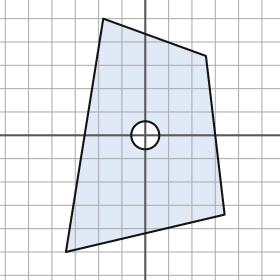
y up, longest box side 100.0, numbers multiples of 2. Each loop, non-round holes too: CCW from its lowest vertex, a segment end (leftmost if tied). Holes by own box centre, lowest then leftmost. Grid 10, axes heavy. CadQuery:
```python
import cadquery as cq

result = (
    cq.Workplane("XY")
    .moveTo(-34.0, -50.0)
    .lineTo(34.0, -34.0)
    .lineTo(26.0, 34.0)
    .lineTo(-18.0, 50.0)
    .close()
    .moveTo(0.0, 0.0)
    .circle(6.0)
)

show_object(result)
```